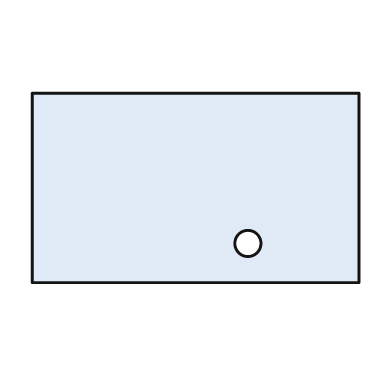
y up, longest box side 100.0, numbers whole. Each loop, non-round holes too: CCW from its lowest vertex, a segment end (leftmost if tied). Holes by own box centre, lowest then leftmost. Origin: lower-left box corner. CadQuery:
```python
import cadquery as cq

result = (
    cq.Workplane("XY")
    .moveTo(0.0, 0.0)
    .lineTo(100.0, 0.0)
    .lineTo(100.0, 58.0)
    .lineTo(0.0, 58.0)
    .close()
    .moveTo(66.0, 12.0)
    .circle(4.0)
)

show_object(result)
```